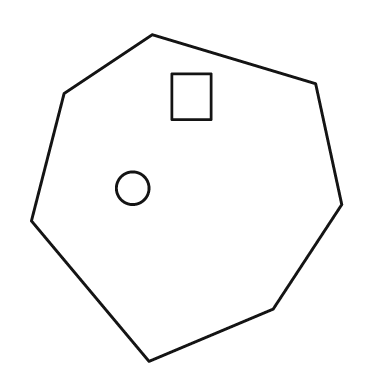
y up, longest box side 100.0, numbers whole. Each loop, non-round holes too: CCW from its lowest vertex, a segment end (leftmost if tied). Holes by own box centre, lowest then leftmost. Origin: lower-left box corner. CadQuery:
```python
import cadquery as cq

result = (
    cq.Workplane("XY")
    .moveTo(36.0, 0.0)
    .lineTo(74.0, 16.0)
    .lineTo(95.0, 48.0)
    .lineTo(87.0, 85.0)
    .lineTo(37.0, 100.0)
    .lineTo(10.0, 82.0)
    .lineTo(0.0, 43.0)
    .close()
    .moveTo(31.0, 53.0)
    .circle(5.0)
    .moveTo(43.0, 74.0)
    .lineTo(55.0, 74.0)
    .lineTo(55.0, 88.0)
    .lineTo(43.0, 88.0)
    .close()
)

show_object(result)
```